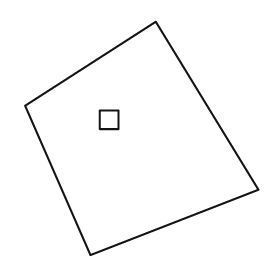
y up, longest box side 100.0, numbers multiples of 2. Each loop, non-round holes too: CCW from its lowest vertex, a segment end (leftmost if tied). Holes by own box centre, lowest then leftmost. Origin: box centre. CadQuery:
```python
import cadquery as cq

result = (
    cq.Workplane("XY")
    .moveTo(-22.0, -50.0)
    .lineTo(50.0, -22.0)
    .lineTo(6.0, 50.0)
    .lineTo(-50.0, 14.0)
    .close()
    .moveTo(-18.0, 4.0)
    .lineTo(-10.0, 4.0)
    .lineTo(-10.0, 12.0)
    .lineTo(-18.0, 12.0)
    .close()
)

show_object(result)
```